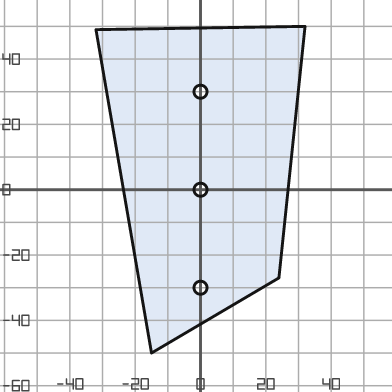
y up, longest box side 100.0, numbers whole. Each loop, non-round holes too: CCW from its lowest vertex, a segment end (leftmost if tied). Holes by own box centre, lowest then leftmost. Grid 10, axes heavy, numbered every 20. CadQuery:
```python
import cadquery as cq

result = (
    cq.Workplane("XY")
    .moveTo(-15.0, -50.0)
    .lineTo(24.0, -27.0)
    .lineTo(32.0, 50.0)
    .lineTo(-32.0, 49.0)
    .close()
    .moveTo(0.0, -30.0)
    .circle(2.0)
    .moveTo(0.0, 0.0)
    .circle(2.0)
    .moveTo(0.0, 30.0)
    .circle(2.0)
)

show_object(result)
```